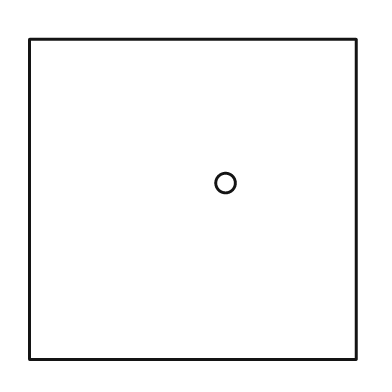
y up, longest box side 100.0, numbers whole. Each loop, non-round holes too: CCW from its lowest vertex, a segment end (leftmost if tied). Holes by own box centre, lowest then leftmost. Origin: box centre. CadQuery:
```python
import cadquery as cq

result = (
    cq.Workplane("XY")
    .moveTo(-50.0, -49.0)
    .lineTo(50.0, -49.0)
    .lineTo(50.0, 49.0)
    .lineTo(-50.0, 49.0)
    .close()
    .moveTo(10.0, 5.0)
    .circle(3.0)
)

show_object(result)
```